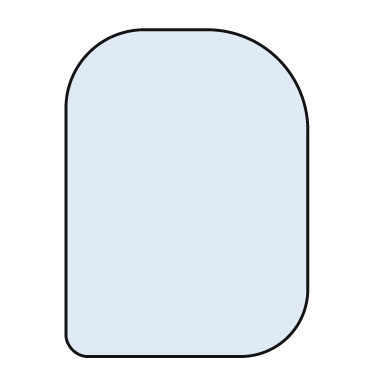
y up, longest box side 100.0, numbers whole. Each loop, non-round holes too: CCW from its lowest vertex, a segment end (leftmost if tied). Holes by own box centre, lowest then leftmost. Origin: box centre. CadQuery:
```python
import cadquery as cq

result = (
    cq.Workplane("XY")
    .moveTo(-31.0, -50.0)
    .lineTo(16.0, -50.0)
    .threePointArc((31.0, -44.0), (37.0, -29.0))
    .lineTo(37.0, 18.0)
    .threePointArc((28.0, 41.0), (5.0, 50.0))
    .lineTo(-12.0, 50.0)
    .threePointArc((-30.0, 43.0), (-37.0, 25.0))
    .lineTo(-37.0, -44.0)
    .threePointArc((-35.0, -48.0), (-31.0, -50.0))
    .close()
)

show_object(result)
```